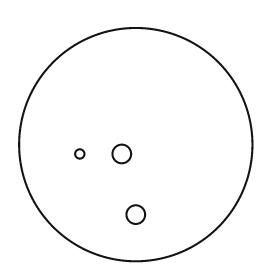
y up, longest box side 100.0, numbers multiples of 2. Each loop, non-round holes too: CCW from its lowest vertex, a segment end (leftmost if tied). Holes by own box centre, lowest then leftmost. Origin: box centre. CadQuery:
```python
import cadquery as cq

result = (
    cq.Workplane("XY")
    .moveTo(0.0, 0.0)
    .circle(50.0)
    .moveTo(0.0, -30.0)
    .circle(4.0)
    .moveTo(-24.0, -4.0)
    .circle(2.0)
    .moveTo(-6.0, -4.0)
    .circle(4.0)
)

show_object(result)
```